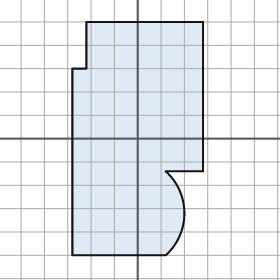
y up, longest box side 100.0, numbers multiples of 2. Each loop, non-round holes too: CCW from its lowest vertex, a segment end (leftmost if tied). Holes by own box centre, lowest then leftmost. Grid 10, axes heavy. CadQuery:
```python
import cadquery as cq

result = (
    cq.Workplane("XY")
    .moveTo(-28.0, -50.0)
    .lineTo(12.0, -50.0)
    .threePointArc((20.0, -32.0), (12.0, -14.0))
    .lineTo(28.0, -14.0)
    .lineTo(28.0, 50.0)
    .lineTo(-22.0, 50.0)
    .lineTo(-22.0, 30.0)
    .lineTo(-28.0, 30.0)
    .close()
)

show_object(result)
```